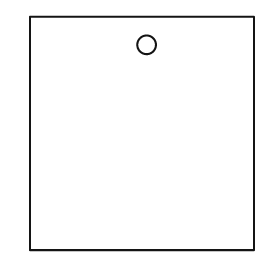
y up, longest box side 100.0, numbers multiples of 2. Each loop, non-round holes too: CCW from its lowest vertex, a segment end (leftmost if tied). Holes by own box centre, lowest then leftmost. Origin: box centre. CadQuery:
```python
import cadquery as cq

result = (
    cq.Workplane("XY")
    .moveTo(-48.0, -50.0)
    .lineTo(48.0, -50.0)
    .lineTo(48.0, 50.0)
    .lineTo(-48.0, 50.0)
    .close()
    .moveTo(2.0, 38.0)
    .circle(4.0)
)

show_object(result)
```